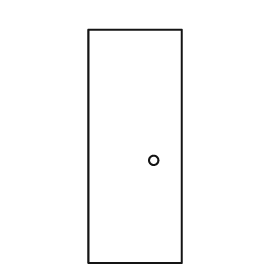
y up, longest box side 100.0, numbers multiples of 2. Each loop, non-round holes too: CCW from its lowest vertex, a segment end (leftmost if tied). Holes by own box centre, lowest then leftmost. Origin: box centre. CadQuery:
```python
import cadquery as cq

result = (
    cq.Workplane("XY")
    .moveTo(-20.0, -50.0)
    .lineTo(20.0, -50.0)
    .lineTo(20.0, 50.0)
    .lineTo(-20.0, 50.0)
    .close()
    .moveTo(8.0, -6.0)
    .circle(2.0)
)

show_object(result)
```